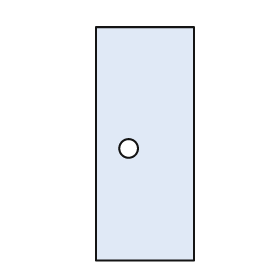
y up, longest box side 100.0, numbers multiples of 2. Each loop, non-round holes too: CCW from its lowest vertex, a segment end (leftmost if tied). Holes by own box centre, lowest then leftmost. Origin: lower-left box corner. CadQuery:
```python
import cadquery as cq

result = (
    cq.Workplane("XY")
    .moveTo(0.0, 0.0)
    .lineTo(42.0, 0.0)
    .lineTo(42.0, 100.0)
    .lineTo(0.0, 100.0)
    .close()
    .moveTo(14.0, 48.0)
    .circle(4.0)
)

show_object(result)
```